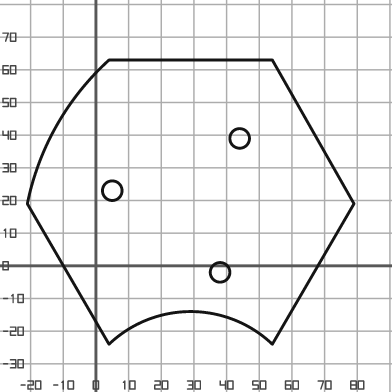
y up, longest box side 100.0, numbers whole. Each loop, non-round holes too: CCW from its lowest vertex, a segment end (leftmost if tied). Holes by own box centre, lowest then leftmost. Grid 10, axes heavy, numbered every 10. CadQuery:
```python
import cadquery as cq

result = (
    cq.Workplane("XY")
    .moveTo(4.0, -24.0)
    .threePointArc((29.0, -14.0), (54.0, -24.0))
    .lineTo(79.0, 19.0)
    .lineTo(54.0, 63.0)
    .lineTo(4.0, 63.0)
    .threePointArc((-12.0, 43.0), (-21.0, 19.0))
    .close()
    .moveTo(38.0, -2.0)
    .circle(3.0)
    .moveTo(5.0, 23.0)
    .circle(3.0)
    .moveTo(44.0, 39.0)
    .circle(3.0)
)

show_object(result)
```